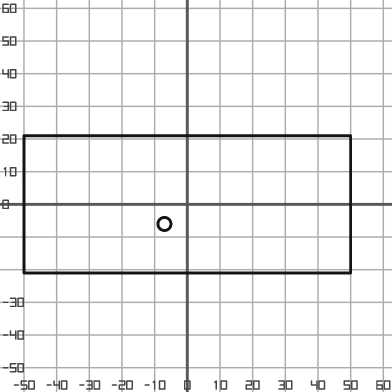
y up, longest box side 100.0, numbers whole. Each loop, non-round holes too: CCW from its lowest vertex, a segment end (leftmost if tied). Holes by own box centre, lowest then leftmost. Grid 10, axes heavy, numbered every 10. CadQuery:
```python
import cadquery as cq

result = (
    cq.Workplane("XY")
    .moveTo(-50.0, -21.0)
    .lineTo(50.0, -21.0)
    .lineTo(50.0, 21.0)
    .lineTo(-50.0, 21.0)
    .close()
    .moveTo(-7.0, -6.0)
    .circle(2.0)
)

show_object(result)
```